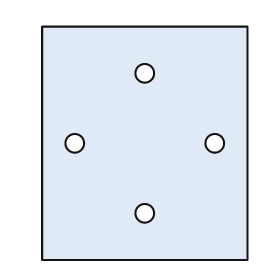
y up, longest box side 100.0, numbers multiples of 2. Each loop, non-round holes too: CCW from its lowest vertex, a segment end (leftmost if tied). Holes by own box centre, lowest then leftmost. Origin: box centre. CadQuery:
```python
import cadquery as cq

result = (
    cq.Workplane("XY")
    .moveTo(-44.0, -50.0)
    .lineTo(44.0, -50.0)
    .lineTo(44.0, 50.0)
    .lineTo(-44.0, 50.0)
    .close()
    .moveTo(0.0, -30.0)
    .circle(4.0)
    .moveTo(-30.0, 0.0)
    .circle(4.0)
    .moveTo(30.0, 0.0)
    .circle(4.0)
    .moveTo(0.0, 30.0)
    .circle(4.0)
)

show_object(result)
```